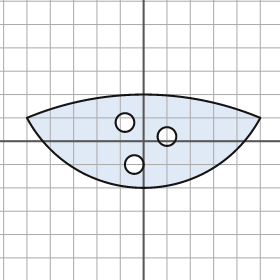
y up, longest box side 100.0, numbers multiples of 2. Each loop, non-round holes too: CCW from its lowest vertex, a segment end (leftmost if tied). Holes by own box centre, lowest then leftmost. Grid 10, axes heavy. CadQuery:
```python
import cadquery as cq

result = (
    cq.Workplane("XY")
    .moveTo(-50.0, 10.0)
    .threePointArc((0.0, -20.0), (50.0, 10.0))
    .threePointArc((0.0, 20.0), (-50.0, 10.0))
    .close()
    .moveTo(-4.0, -10.0)
    .circle(4.0)
    .moveTo(10.0, 2.0)
    .circle(4.0)
    .moveTo(-8.0, 8.0)
    .circle(4.0)
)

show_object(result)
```